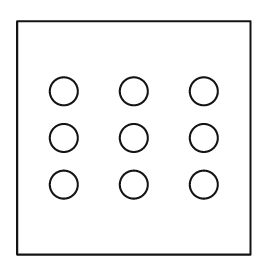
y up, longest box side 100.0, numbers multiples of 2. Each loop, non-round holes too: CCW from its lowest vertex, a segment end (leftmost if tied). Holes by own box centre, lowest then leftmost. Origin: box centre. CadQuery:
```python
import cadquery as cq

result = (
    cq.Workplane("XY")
    .moveTo(-50.0, -50.0)
    .lineTo(50.0, -50.0)
    .lineTo(50.0, 50.0)
    .lineTo(-50.0, 50.0)
    .close()
    .moveTo(-30.0, -20.0)
    .circle(6.0)
    .moveTo(0.0, -20.0)
    .circle(6.0)
    .moveTo(30.0, -20.0)
    .circle(6.0)
    .moveTo(-30.0, 0.0)
    .circle(6.0)
    .moveTo(0.0, 0.0)
    .circle(6.0)
    .moveTo(30.0, 0.0)
    .circle(6.0)
    .moveTo(-30.0, 20.0)
    .circle(6.0)
    .moveTo(0.0, 20.0)
    .circle(6.0)
    .moveTo(30.0, 20.0)
    .circle(6.0)
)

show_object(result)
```